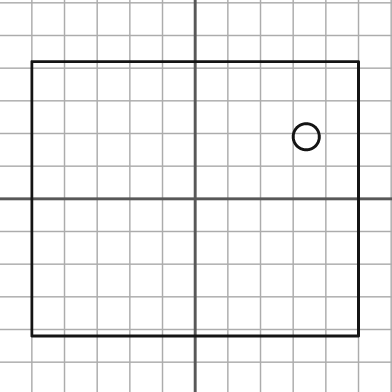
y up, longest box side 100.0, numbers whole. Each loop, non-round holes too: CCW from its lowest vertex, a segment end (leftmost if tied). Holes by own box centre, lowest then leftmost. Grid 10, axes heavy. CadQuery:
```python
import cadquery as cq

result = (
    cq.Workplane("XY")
    .moveTo(-50.0, -42.0)
    .lineTo(50.0, -42.0)
    .lineTo(50.0, 42.0)
    .lineTo(-50.0, 42.0)
    .close()
    .moveTo(34.0, 19.0)
    .circle(4.0)
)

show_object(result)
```